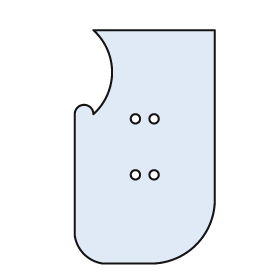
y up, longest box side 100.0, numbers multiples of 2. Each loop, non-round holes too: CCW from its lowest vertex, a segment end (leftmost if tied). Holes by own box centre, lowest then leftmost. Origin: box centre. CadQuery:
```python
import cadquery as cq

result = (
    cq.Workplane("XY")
    .moveTo(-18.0, -50.0)
    .lineTo(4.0, -50.0)
    .threePointArc((22.0, -42.0), (30.0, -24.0))
    .lineTo(30.0, 50.0)
    .lineTo(-22.0, 50.0)
    .threePointArc((-14.0, 32.0), (-22.0, 14.0))
    .threePointArc((-26.0, 18.0), (-30.0, 14.0))
    .lineTo(-30.0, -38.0)
    .threePointArc((-26.0, -46.0), (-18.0, -50.0))
    .close()
    .moveTo(-4.0, -12.0)
    .circle(2.0)
    .moveTo(4.0, -12.0)
    .circle(2.0)
    .moveTo(-4.0, 12.0)
    .circle(2.0)
    .moveTo(4.0, 12.0)
    .circle(2.0)
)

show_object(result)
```